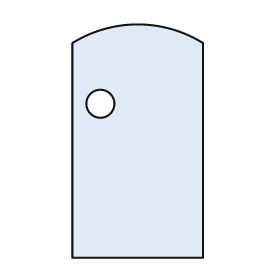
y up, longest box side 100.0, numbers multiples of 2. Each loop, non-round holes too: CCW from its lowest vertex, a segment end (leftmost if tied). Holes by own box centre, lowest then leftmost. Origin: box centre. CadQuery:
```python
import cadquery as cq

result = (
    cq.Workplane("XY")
    .moveTo(-28.0, -50.0)
    .lineTo(28.0, -50.0)
    .lineTo(28.0, 42.0)
    .threePointArc((0.0, 50.0), (-28.0, 42.0))
    .close()
    .moveTo(-16.0, 16.0)
    .circle(6.0)
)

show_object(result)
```